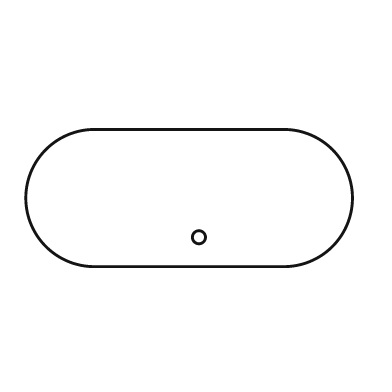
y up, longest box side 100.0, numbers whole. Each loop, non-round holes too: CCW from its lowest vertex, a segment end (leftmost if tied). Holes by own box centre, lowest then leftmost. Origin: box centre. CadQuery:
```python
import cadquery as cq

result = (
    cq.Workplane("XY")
    .moveTo(-29.0, -21.0)
    .lineTo(29.0, -21.0)
    .threePointArc((50.0, 0.0), (29.0, 21.0))
    .lineTo(-29.0, 21.0)
    .threePointArc((-50.0, 0.0), (-29.0, -21.0))
    .close()
    .moveTo(3.0, -12.0)
    .circle(2.0)
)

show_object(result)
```